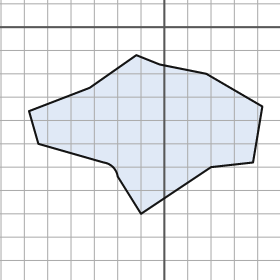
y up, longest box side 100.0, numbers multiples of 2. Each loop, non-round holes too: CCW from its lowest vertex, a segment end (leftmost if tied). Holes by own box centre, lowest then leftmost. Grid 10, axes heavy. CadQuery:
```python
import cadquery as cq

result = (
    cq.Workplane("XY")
    .moveTo(-10.0, -80.0)
    .lineTo(20.0, -60.0)
    .lineTo(38.0, -58.0)
    .lineTo(42.0, -34.0)
    .lineTo(18.0, -20.0)
    .lineTo(-2.0, -16.0)
    .lineTo(-12.0, -12.0)
    .lineTo(-32.0, -26.0)
    .lineTo(-58.0, -36.0)
    .lineTo(-54.0, -50.0)
    .lineTo(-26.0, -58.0)
    .threePointArc((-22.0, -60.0), (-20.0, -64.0))
    .close()
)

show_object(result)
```